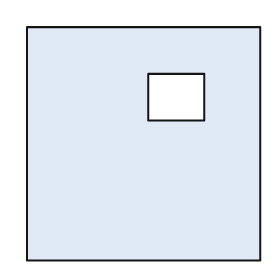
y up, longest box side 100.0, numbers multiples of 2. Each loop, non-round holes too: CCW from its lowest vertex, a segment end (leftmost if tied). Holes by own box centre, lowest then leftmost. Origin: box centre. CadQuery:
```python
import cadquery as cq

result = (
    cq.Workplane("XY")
    .moveTo(-50.0, -50.0)
    .lineTo(50.0, -50.0)
    .lineTo(50.0, 50.0)
    .lineTo(-50.0, 50.0)
    .close()
    .moveTo(2.0, 10.0)
    .lineTo(26.0, 10.0)
    .lineTo(26.0, 30.0)
    .lineTo(2.0, 30.0)
    .close()
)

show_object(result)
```